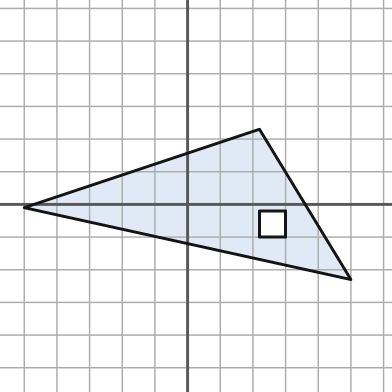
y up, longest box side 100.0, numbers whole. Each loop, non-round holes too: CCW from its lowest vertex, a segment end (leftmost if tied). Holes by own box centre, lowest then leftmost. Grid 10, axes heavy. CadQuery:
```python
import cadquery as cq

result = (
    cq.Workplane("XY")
    .moveTo(50.0, -23.0)
    .lineTo(22.0, 23.0)
    .lineTo(-50.0, -1.0)
    .close()
    .moveTo(22.0, -10.0)
    .lineTo(30.0, -10.0)
    .lineTo(30.0, -2.0)
    .lineTo(22.0, -2.0)
    .close()
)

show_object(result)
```